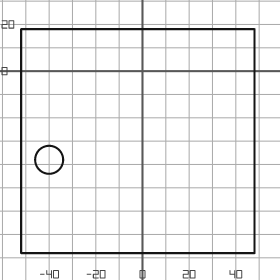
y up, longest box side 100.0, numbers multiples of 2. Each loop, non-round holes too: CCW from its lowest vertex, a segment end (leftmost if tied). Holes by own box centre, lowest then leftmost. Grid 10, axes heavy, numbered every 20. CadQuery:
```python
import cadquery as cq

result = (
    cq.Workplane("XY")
    .moveTo(-52.0, -78.0)
    .lineTo(48.0, -78.0)
    .lineTo(48.0, 18.0)
    .lineTo(-52.0, 18.0)
    .close()
    .moveTo(-40.0, -38.0)
    .circle(6.0)
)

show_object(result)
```